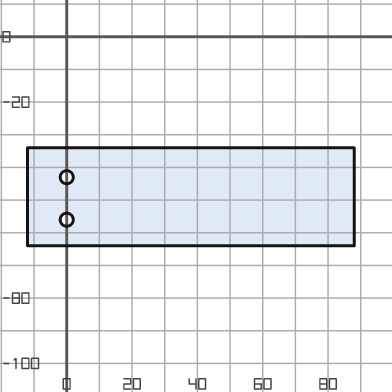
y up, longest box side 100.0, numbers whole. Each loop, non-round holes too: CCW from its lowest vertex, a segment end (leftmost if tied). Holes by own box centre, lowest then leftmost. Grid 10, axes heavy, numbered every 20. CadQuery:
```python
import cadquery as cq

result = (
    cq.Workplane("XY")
    .moveTo(-12.0, -64.0)
    .lineTo(88.0, -64.0)
    .lineTo(88.0, -34.0)
    .lineTo(-12.0, -34.0)
    .close()
    .moveTo(0.0, -56.0)
    .circle(2.0)
    .moveTo(0.0, -43.0)
    .circle(2.0)
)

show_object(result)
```